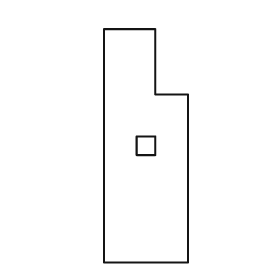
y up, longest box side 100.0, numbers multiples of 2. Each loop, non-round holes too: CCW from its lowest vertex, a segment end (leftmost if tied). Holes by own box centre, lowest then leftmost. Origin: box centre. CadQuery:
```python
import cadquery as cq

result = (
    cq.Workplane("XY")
    .moveTo(-18.0, -50.0)
    .lineTo(18.0, -50.0)
    .lineTo(18.0, 22.0)
    .lineTo(4.0, 22.0)
    .lineTo(4.0, 50.0)
    .lineTo(-18.0, 50.0)
    .close()
    .moveTo(-4.0, -4.0)
    .lineTo(4.0, -4.0)
    .lineTo(4.0, 4.0)
    .lineTo(-4.0, 4.0)
    .close()
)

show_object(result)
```